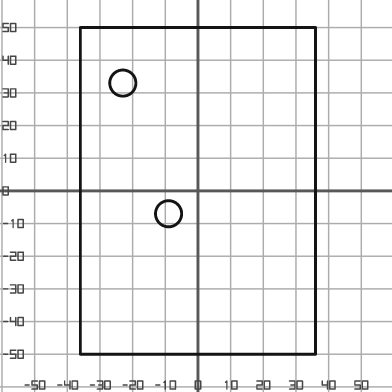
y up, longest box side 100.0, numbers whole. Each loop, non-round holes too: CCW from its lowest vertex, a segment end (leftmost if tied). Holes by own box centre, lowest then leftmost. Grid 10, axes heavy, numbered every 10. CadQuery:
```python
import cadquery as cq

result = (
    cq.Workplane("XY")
    .moveTo(-36.0, -50.0)
    .lineTo(36.0, -50.0)
    .lineTo(36.0, 50.0)
    .lineTo(-36.0, 50.0)
    .close()
    .moveTo(-9.0, -7.0)
    .circle(4.0)
    .moveTo(-23.0, 33.0)
    .circle(4.0)
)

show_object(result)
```